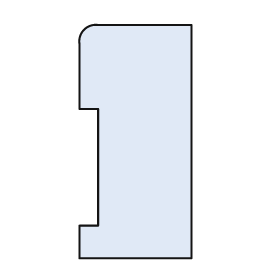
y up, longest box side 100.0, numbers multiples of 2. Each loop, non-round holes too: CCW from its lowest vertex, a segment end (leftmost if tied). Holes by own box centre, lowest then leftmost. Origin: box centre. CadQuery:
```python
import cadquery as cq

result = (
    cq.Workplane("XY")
    .moveTo(-24.0, -50.0)
    .lineTo(24.0, -50.0)
    .lineTo(24.0, 50.0)
    .lineTo(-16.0, 50.0)
    .threePointArc((-22.0, 48.0), (-24.0, 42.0))
    .lineTo(-24.0, 14.0)
    .lineTo(-16.0, 14.0)
    .lineTo(-16.0, -36.0)
    .lineTo(-24.0, -36.0)
    .close()
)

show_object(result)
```